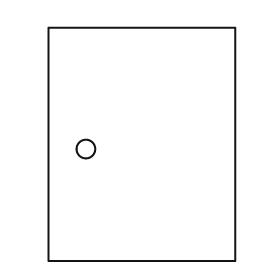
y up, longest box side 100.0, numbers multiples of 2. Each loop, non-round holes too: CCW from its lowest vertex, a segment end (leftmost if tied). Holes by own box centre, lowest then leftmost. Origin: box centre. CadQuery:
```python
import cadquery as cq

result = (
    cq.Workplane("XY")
    .moveTo(-40.0, -50.0)
    .lineTo(40.0, -50.0)
    .lineTo(40.0, 50.0)
    .lineTo(-40.0, 50.0)
    .close()
    .moveTo(-24.0, -2.0)
    .circle(4.0)
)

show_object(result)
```